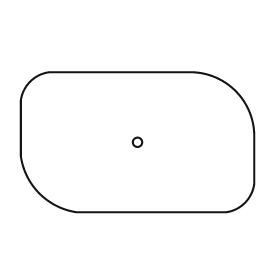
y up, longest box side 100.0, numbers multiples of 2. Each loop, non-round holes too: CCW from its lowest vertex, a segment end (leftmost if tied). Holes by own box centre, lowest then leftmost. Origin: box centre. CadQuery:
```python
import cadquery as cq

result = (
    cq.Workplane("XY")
    .moveTo(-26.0, -30.0)
    .lineTo(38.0, -30.0)
    .threePointArc((46.0, -26.0), (50.0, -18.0))
    .lineTo(50.0, 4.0)
    .threePointArc((42.0, 22.0), (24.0, 30.0))
    .lineTo(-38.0, 30.0)
    .threePointArc((-46.0, 26.0), (-50.0, 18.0))
    .lineTo(-50.0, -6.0)
    .threePointArc((-42.0, -22.0), (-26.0, -30.0))
    .close()
    .moveTo(0.0, 0.0)
    .circle(2.0)
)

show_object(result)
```